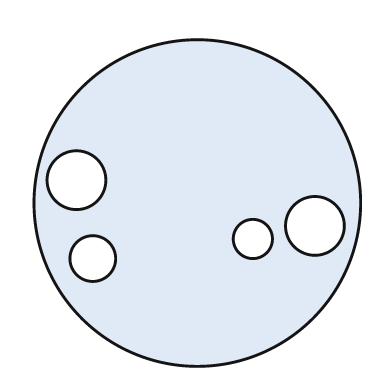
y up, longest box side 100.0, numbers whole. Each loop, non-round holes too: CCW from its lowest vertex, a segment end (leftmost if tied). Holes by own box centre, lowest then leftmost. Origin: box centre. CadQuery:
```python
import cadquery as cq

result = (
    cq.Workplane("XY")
    .moveTo(0.0, 0.0)
    .circle(50.0)
    .moveTo(-32.0, -17.0)
    .circle(7.0)
    .moveTo(17.0, -11.0)
    .circle(6.0)
    .moveTo(36.0, -7.0)
    .circle(9.0)
    .moveTo(-37.0, 7.0)
    .circle(9.0)
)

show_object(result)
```